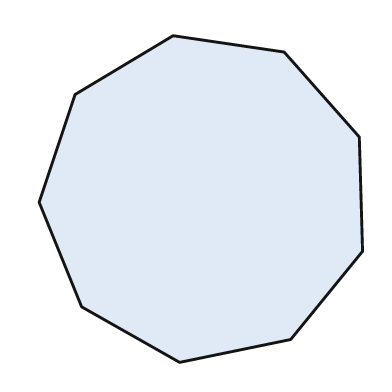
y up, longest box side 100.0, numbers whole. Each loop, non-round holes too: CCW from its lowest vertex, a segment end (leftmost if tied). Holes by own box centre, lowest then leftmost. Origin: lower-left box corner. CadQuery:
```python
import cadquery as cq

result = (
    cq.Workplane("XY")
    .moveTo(43.0, 0.0)
    .lineTo(77.0, 7.0)
    .lineTo(99.0, 34.0)
    .lineTo(98.0, 69.0)
    .lineTo(75.0, 95.0)
    .lineTo(41.0, 100.0)
    .lineTo(11.0, 82.0)
    .lineTo(0.0, 49.0)
    .lineTo(13.0, 17.0)
    .close()
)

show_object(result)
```